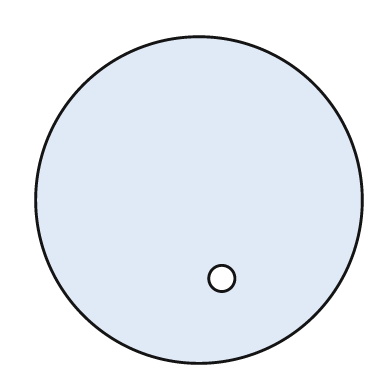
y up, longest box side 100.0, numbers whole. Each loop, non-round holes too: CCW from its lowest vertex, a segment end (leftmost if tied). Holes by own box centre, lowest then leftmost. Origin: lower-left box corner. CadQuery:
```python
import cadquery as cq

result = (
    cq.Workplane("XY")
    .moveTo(50.0, 50.0)
    .circle(50.0)
    .moveTo(57.0, 26.0)
    .circle(4.0)
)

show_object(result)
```